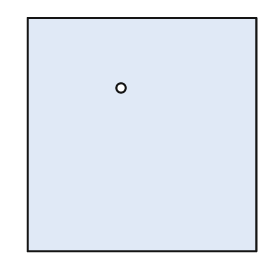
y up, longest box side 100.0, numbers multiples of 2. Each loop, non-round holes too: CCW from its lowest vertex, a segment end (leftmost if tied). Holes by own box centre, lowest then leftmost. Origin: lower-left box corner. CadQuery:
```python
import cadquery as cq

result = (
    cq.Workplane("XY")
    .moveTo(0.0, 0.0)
    .lineTo(98.0, 0.0)
    .lineTo(98.0, 100.0)
    .lineTo(0.0, 100.0)
    .close()
    .moveTo(40.0, 70.0)
    .circle(2.0)
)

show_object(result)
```